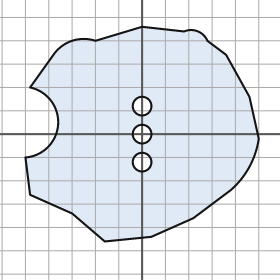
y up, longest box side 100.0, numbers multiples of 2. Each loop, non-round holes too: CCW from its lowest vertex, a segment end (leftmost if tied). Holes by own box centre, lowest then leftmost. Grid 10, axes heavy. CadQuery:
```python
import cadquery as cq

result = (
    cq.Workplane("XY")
    .moveTo(-16.0, -46.0)
    .lineTo(4.0, -44.0)
    .lineTo(22.0, -36.0)
    .lineTo(38.0, -24.0)
    .threePointArc((46.0, -14.0), (50.0, -2.0))
    .lineTo(46.0, 16.0)
    .lineTo(36.0, 34.0)
    .lineTo(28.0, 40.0)
    .threePointArc((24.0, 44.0), (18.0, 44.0))
    .lineTo(0.0, 46.0)
    .lineTo(-20.0, 40.0)
    .threePointArc((-30.0, 40.0), (-38.0, 34.0))
    .lineTo(-48.0, 20.0)
    .threePointArc((-36.0, 4.0), (-50.0, -10.0))
    .lineTo(-48.0, -26.0)
    .lineTo(-30.0, -34.0)
    .close()
    .moveTo(0.0, -12.0)
    .circle(4.0)
    .moveTo(0.0, 0.0)
    .circle(4.0)
    .moveTo(0.0, 12.0)
    .circle(4.0)
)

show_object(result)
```